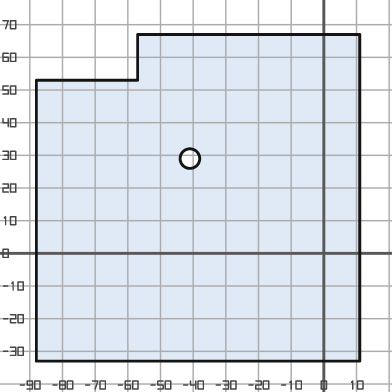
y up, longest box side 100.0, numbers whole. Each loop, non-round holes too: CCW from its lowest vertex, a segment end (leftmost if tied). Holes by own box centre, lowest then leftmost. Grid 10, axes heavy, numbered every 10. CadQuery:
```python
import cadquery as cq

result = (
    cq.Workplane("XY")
    .moveTo(-88.0, -33.0)
    .lineTo(11.0, -33.0)
    .lineTo(11.0, 67.0)
    .lineTo(-57.0, 67.0)
    .lineTo(-57.0, 53.0)
    .lineTo(-88.0, 53.0)
    .close()
    .moveTo(-41.0, 29.0)
    .circle(3.0)
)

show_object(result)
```